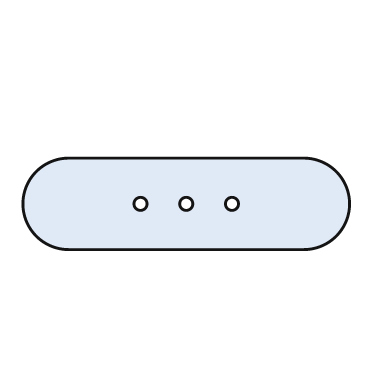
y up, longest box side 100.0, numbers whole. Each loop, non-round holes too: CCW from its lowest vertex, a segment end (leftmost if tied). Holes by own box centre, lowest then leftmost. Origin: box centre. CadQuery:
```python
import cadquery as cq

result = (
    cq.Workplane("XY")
    .moveTo(-36.0, -14.0)
    .lineTo(36.0, -14.0)
    .threePointArc((50.0, 0.0), (36.0, 14.0))
    .lineTo(-36.0, 14.0)
    .threePointArc((-50.0, 0.0), (-36.0, -14.0))
    .close()
    .moveTo(-14.0, 0.0)
    .circle(2.0)
    .moveTo(0.0, 0.0)
    .circle(2.0)
    .moveTo(14.0, 0.0)
    .circle(2.0)
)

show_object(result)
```